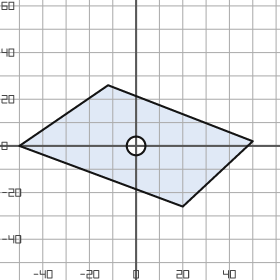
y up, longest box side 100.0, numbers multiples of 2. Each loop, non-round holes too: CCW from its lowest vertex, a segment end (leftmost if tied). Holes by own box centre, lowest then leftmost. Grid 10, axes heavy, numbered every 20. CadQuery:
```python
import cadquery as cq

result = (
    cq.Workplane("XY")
    .moveTo(20.0, -26.0)
    .lineTo(50.0, 2.0)
    .lineTo(-12.0, 26.0)
    .lineTo(-50.0, 0.0)
    .close()
    .moveTo(0.0, 0.0)
    .circle(4.0)
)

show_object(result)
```